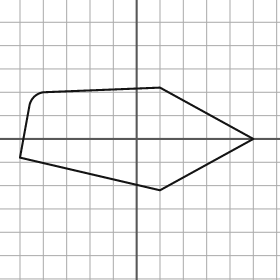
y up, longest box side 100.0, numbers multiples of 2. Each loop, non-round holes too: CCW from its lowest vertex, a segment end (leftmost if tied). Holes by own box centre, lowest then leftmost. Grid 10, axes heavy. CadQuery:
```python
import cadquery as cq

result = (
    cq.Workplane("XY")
    .moveTo(10.0, -22.0)
    .lineTo(50.0, 0.0)
    .lineTo(10.0, 22.0)
    .lineTo(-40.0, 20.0)
    .threePointArc((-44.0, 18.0), (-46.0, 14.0))
    .lineTo(-50.0, -8.0)
    .close()
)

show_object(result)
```